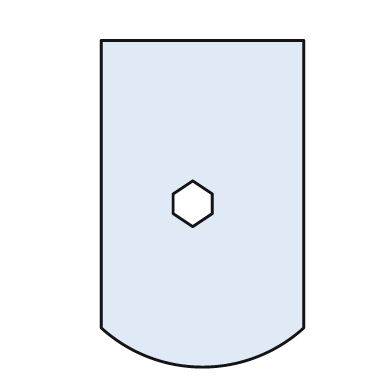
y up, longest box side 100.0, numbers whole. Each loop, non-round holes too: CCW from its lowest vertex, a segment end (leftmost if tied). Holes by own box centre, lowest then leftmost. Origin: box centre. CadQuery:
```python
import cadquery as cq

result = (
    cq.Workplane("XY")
    .moveTo(-31.0, -38.0)
    .threePointArc((0.0, -50.0), (31.0, -38.0))
    .lineTo(31.0, 50.0)
    .lineTo(-31.0, 50.0)
    .close()
    .moveTo(-3.0, -7.0)
    .lineTo(3.0, -3.0)
    .lineTo(3.0, 3.0)
    .lineTo(-3.0, 7.0)
    .lineTo(-9.0, 3.0)
    .lineTo(-9.0, -3.0)
    .close()
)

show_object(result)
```